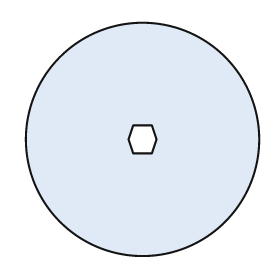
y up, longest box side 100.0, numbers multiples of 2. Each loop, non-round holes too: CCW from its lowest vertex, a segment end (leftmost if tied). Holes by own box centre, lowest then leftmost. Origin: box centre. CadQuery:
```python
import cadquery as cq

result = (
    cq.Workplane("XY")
    .moveTo(0.0, 0.0)
    .circle(50.0)
    .moveTo(-4.0, -6.0)
    .lineTo(4.0, -6.0)
    .lineTo(6.0, 0.0)
    .lineTo(4.0, 6.0)
    .lineTo(-4.0, 6.0)
    .lineTo(-6.0, 0.0)
    .close()
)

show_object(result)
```